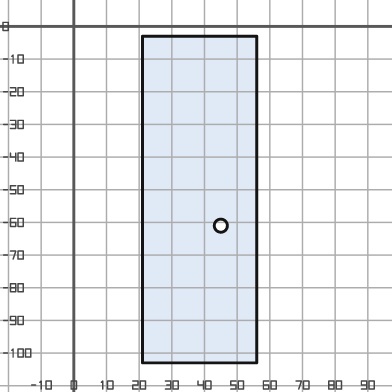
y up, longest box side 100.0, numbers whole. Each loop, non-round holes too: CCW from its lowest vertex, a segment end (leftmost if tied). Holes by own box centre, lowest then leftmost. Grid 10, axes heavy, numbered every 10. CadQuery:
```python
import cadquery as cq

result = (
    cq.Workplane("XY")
    .moveTo(21.0, -103.0)
    .lineTo(56.0, -103.0)
    .lineTo(56.0, -3.0)
    .lineTo(21.0, -3.0)
    .close()
    .moveTo(45.0, -61.0)
    .circle(2.0)
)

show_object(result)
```